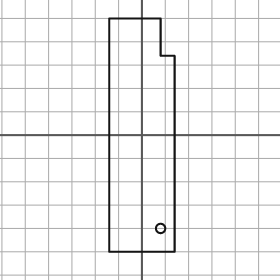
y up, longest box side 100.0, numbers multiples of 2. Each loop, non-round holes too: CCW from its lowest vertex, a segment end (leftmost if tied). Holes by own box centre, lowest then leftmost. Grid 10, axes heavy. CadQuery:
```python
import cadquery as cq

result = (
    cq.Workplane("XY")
    .moveTo(-14.0, -50.0)
    .lineTo(14.0, -50.0)
    .lineTo(14.0, 34.0)
    .lineTo(8.0, 34.0)
    .lineTo(8.0, 50.0)
    .lineTo(-14.0, 50.0)
    .close()
    .moveTo(8.0, -40.0)
    .circle(2.0)
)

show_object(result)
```